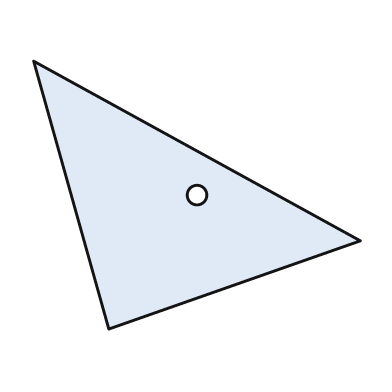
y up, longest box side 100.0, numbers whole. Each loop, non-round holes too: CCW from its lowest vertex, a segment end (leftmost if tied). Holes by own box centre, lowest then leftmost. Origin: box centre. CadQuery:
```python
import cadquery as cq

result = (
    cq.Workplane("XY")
    .moveTo(-27.0, -41.0)
    .lineTo(50.0, -14.0)
    .lineTo(-50.0, 41.0)
    .close()
    .moveTo(0.0, 0.0)
    .circle(3.0)
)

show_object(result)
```